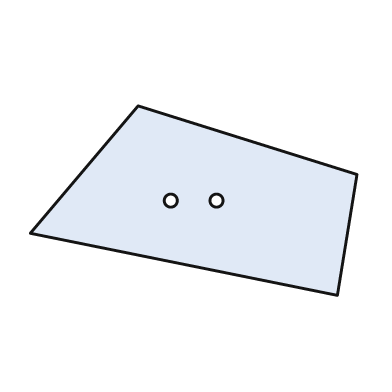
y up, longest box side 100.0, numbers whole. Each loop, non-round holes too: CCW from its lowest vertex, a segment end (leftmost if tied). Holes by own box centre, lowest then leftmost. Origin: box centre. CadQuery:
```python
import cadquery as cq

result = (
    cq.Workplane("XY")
    .moveTo(44.0, -29.0)
    .lineTo(50.0, 8.0)
    .lineTo(-17.0, 29.0)
    .lineTo(-50.0, -10.0)
    .close()
    .moveTo(-7.0, 0.0)
    .circle(2.0)
    .moveTo(7.0, 0.0)
    .circle(2.0)
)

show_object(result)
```